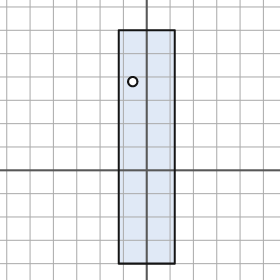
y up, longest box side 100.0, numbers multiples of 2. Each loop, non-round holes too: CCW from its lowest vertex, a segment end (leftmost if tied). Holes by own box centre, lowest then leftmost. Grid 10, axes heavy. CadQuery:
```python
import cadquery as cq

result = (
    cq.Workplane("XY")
    .moveTo(-12.0, -40.0)
    .lineTo(12.0, -40.0)
    .lineTo(12.0, 60.0)
    .lineTo(-12.0, 60.0)
    .close()
    .moveTo(-6.0, 38.0)
    .circle(2.0)
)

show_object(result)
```